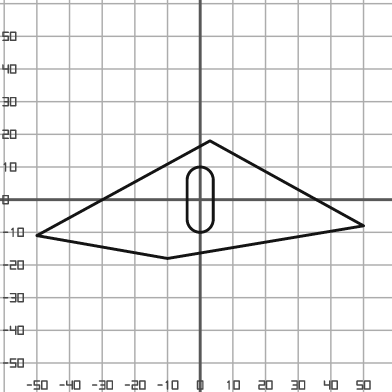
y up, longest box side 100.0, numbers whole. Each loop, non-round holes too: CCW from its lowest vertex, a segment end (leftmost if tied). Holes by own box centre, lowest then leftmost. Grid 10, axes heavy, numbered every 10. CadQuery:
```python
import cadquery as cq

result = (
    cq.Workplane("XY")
    .moveTo(-10.0, -18.0)
    .lineTo(50.0, -8.0)
    .lineTo(3.0, 18.0)
    .lineTo(-50.0, -11.0)
    .close()
    .moveTo(-4.0, -6.0)
    .threePointArc((0.0, -10.0), (4.0, -6.0))
    .lineTo(4.0, 6.0)
    .threePointArc((0.0, 10.0), (-4.0, 6.0))
    .close()
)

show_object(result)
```